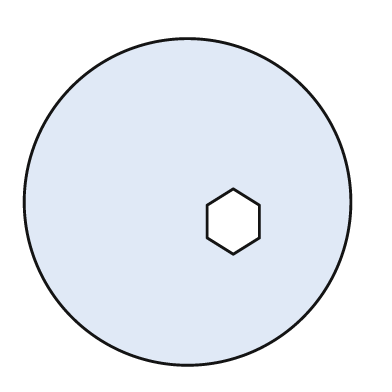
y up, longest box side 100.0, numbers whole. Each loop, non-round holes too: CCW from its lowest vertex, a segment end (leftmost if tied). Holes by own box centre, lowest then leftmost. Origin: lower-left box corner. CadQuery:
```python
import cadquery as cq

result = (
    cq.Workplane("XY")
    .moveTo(50.0, 50.0)
    .circle(50.0)
    .moveTo(64.0, 34.0)
    .lineTo(72.0, 39.0)
    .lineTo(72.0, 49.0)
    .lineTo(64.0, 54.0)
    .lineTo(56.0, 49.0)
    .lineTo(56.0, 39.0)
    .close()
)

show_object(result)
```